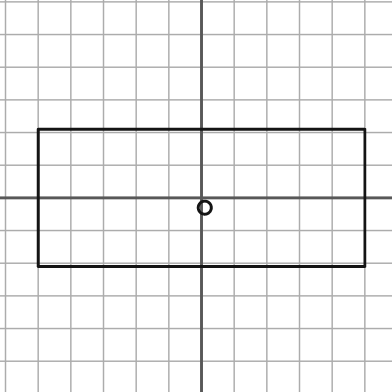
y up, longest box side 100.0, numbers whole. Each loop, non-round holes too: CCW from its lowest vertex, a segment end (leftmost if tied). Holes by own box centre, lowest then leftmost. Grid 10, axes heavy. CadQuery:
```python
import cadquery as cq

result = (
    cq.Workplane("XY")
    .moveTo(-50.0, -21.0)
    .lineTo(50.0, -21.0)
    .lineTo(50.0, 21.0)
    .lineTo(-50.0, 21.0)
    .close()
    .moveTo(1.0, -3.0)
    .circle(2.0)
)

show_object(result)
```